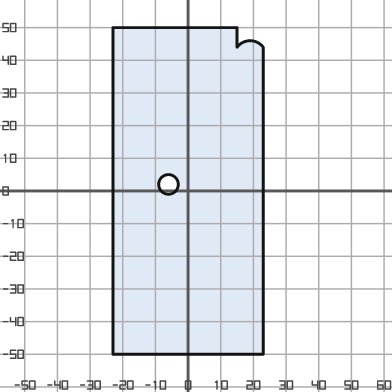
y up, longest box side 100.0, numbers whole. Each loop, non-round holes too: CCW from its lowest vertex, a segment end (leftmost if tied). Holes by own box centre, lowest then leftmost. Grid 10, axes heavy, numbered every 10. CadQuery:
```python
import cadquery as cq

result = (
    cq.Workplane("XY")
    .moveTo(-23.0, -50.0)
    .lineTo(23.0, -50.0)
    .lineTo(23.0, 44.0)
    .threePointArc((19.0, 46.0), (15.0, 44.0))
    .lineTo(15.0, 50.0)
    .lineTo(-23.0, 50.0)
    .close()
    .moveTo(-6.0, 2.0)
    .circle(3.0)
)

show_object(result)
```